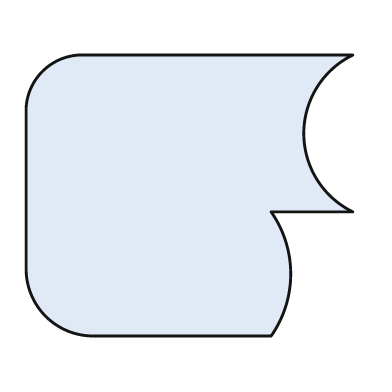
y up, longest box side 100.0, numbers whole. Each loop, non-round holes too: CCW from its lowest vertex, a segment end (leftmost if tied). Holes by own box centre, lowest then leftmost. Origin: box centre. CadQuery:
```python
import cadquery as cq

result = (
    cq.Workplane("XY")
    .moveTo(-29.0, -43.0)
    .lineTo(25.0, -43.0)
    .threePointArc((31.0, -24.0), (25.0, -5.0))
    .lineTo(50.0, -5.0)
    .threePointArc((35.0, 19.0), (50.0, 43.0))
    .lineTo(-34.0, 43.0)
    .threePointArc((-45.0, 38.0), (-50.0, 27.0))
    .lineTo(-50.0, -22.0)
    .threePointArc((-44.0, -37.0), (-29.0, -43.0))
    .close()
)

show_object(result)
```